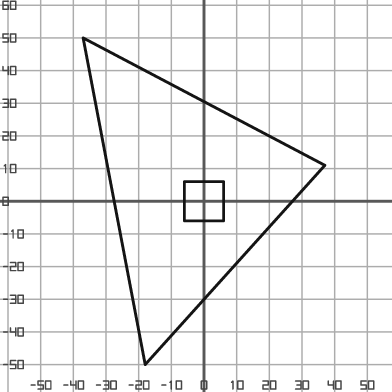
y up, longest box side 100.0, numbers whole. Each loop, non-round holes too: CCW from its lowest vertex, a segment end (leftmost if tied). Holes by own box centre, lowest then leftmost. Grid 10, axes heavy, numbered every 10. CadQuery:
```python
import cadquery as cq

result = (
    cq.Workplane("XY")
    .moveTo(-18.0, -50.0)
    .lineTo(37.0, 11.0)
    .lineTo(-37.0, 50.0)
    .close()
    .moveTo(-6.0, -6.0)
    .lineTo(6.0, -6.0)
    .lineTo(6.0, 6.0)
    .lineTo(-6.0, 6.0)
    .close()
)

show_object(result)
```